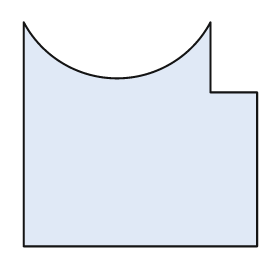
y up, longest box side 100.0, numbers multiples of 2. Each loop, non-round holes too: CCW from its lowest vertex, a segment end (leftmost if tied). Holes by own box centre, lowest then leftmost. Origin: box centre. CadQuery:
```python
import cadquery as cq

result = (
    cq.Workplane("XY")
    .moveTo(-50.0, -48.0)
    .lineTo(50.0, -48.0)
    .lineTo(50.0, 18.0)
    .lineTo(30.0, 18.0)
    .lineTo(30.0, 48.0)
    .threePointArc((-10.0, 24.0), (-50.0, 48.0))
    .close()
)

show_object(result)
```